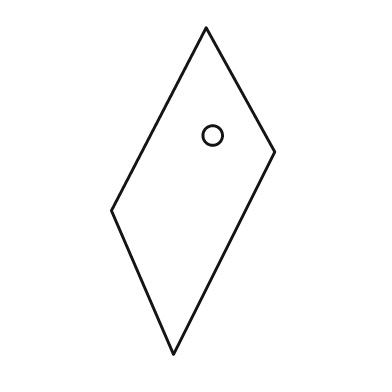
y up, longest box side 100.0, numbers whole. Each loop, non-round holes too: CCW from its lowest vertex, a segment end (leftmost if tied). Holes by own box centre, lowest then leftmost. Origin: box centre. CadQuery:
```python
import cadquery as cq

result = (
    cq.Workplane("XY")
    .moveTo(-6.0, -50.0)
    .lineTo(25.0, 12.0)
    .lineTo(4.0, 50.0)
    .lineTo(-25.0, -6.0)
    .close()
    .moveTo(6.0, 17.0)
    .circle(3.0)
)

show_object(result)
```